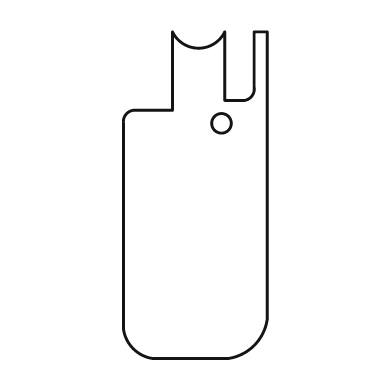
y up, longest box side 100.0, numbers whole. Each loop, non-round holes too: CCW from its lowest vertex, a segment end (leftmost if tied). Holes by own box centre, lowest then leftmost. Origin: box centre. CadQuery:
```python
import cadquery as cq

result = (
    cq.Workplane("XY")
    .moveTo(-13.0, -50.0)
    .lineTo(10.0, -50.0)
    .threePointArc((18.0, -46.0), (22.0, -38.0))
    .lineTo(22.0, 50.0)
    .lineTo(18.0, 50.0)
    .lineTo(18.0, 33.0)
    .threePointArc((17.0, 30.0), (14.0, 29.0))
    .lineTo(9.0, 29.0)
    .lineTo(9.0, 50.0)
    .threePointArc((1.0, 45.0), (-7.0, 50.0))
    .lineTo(-7.0, 26.0)
    .lineTo(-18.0, 26.0)
    .threePointArc((-21.0, 25.0), (-22.0, 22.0))
    .lineTo(-22.0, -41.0)
    .threePointArc((-19.0, -47.0), (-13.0, -50.0))
    .close()
    .moveTo(8.0, 22.0)
    .circle(3.0)
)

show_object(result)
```